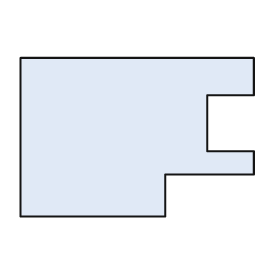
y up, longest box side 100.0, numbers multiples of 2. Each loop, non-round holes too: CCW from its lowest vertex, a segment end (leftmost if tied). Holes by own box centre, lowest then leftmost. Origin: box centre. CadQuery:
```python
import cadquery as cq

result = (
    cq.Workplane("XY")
    .moveTo(-50.0, -34.0)
    .lineTo(12.0, -34.0)
    .lineTo(12.0, -16.0)
    .lineTo(50.0, -16.0)
    .lineTo(50.0, -6.0)
    .lineTo(30.0, -6.0)
    .lineTo(30.0, 18.0)
    .lineTo(50.0, 18.0)
    .lineTo(50.0, 34.0)
    .lineTo(-50.0, 34.0)
    .close()
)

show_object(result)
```